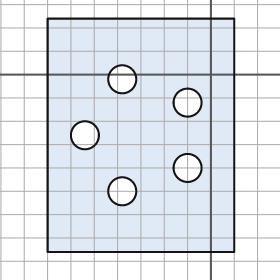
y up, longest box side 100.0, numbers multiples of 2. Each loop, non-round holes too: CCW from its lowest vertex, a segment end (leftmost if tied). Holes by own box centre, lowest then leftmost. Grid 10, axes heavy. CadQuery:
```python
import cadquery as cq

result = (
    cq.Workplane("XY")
    .moveTo(-70.0, -76.0)
    .lineTo(10.0, -76.0)
    .lineTo(10.0, 24.0)
    .lineTo(-70.0, 24.0)
    .close()
    .moveTo(-38.0, -50.0)
    .circle(6.0)
    .moveTo(-10.0, -40.0)
    .circle(6.0)
    .moveTo(-54.0, -26.0)
    .circle(6.0)
    .moveTo(-10.0, -12.0)
    .circle(6.0)
    .moveTo(-38.0, -2.0)
    .circle(6.0)
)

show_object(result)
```